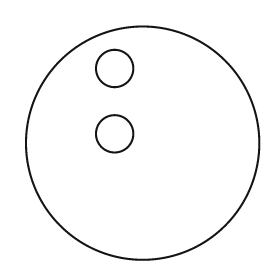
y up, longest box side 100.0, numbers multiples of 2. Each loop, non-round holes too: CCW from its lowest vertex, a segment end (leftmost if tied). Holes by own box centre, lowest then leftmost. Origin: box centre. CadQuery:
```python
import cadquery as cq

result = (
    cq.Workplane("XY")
    .moveTo(0.0, 0.0)
    .circle(50.0)
    .moveTo(-12.0, 4.0)
    .circle(8.0)
    .moveTo(-12.0, 32.0)
    .circle(8.0)
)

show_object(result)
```